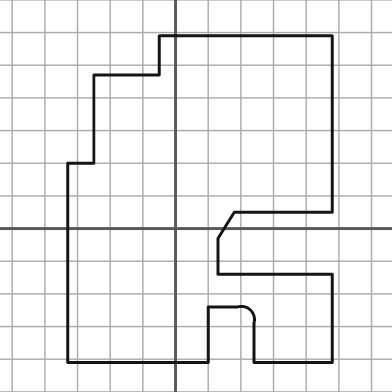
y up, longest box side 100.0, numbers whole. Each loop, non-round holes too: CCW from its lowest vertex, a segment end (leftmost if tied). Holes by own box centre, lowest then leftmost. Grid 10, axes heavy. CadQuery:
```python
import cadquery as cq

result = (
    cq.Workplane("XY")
    .moveTo(-33.0, -41.0)
    .lineTo(10.0, -41.0)
    .lineTo(10.0, -24.0)
    .lineTo(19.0, -24.0)
    .threePointArc((23.0, -25.0), (24.0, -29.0))
    .lineTo(24.0, -41.0)
    .lineTo(48.0, -41.0)
    .lineTo(48.0, -14.0)
    .lineTo(13.0, -14.0)
    .lineTo(13.0, -3.0)
    .lineTo(18.0, 5.0)
    .lineTo(48.0, 5.0)
    .lineTo(48.0, 59.0)
    .lineTo(-5.0, 59.0)
    .lineTo(-5.0, 47.0)
    .lineTo(-25.0, 47.0)
    .lineTo(-25.0, 20.0)
    .lineTo(-33.0, 20.0)
    .close()
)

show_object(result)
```